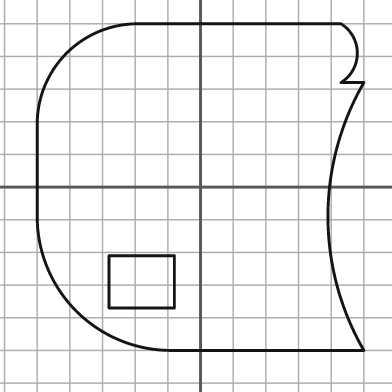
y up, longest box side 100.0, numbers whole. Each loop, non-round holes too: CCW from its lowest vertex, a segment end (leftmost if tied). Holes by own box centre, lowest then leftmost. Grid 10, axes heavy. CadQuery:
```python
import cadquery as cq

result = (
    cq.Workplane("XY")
    .moveTo(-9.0, -50.0)
    .lineTo(50.0, -50.0)
    .threePointArc((39.0, -9.0), (50.0, 32.0))
    .lineTo(43.0, 32.0)
    .threePointArc((48.0, 41.0), (43.0, 50.0))
    .lineTo(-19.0, 50.0)
    .threePointArc((-41.0, 41.0), (-50.0, 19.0))
    .lineTo(-50.0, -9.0)
    .threePointArc((-38.0, -38.0), (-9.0, -50.0))
    .close()
    .moveTo(-28.0, -37.0)
    .lineTo(-8.0, -37.0)
    .lineTo(-8.0, -21.0)
    .lineTo(-28.0, -21.0)
    .close()
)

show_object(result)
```